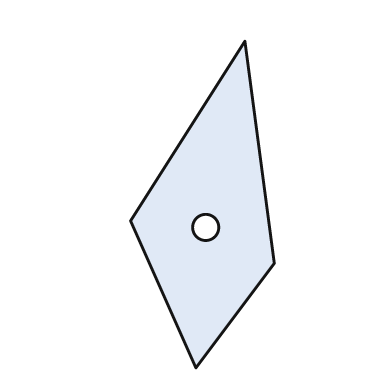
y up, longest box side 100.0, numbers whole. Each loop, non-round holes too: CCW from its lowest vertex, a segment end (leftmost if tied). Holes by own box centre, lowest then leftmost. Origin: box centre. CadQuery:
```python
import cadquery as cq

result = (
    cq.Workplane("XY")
    .moveTo(-2.0, -50.0)
    .lineTo(22.0, -18.0)
    .lineTo(13.0, 50.0)
    .lineTo(-22.0, -5.0)
    .close()
    .moveTo(1.0, -7.0)
    .circle(4.0)
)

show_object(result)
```